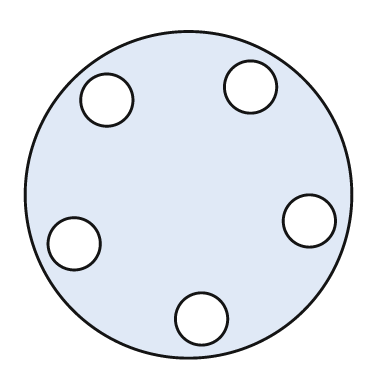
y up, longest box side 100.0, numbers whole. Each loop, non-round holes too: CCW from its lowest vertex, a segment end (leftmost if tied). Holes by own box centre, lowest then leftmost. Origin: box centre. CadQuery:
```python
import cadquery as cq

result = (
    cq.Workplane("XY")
    .moveTo(0.0, 0.0)
    .circle(50.0)
    .moveTo(4.0, -38.0)
    .circle(8.0)
    .moveTo(-35.0, -15.0)
    .circle(8.0)
    .moveTo(37.0, -8.0)
    .circle(8.0)
    .moveTo(-25.0, 29.0)
    .circle(8.0)
    .moveTo(19.0, 33.0)
    .circle(8.0)
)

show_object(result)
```